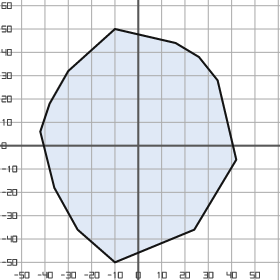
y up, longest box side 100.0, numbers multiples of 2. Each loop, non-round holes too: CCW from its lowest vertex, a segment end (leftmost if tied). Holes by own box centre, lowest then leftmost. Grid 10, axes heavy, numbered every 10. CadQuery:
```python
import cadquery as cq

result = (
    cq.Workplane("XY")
    .moveTo(-10.0, -50.0)
    .lineTo(24.0, -36.0)
    .lineTo(42.0, -6.0)
    .lineTo(34.0, 28.0)
    .lineTo(26.0, 38.0)
    .lineTo(16.0, 44.0)
    .lineTo(-10.0, 50.0)
    .lineTo(-30.0, 32.0)
    .lineTo(-38.0, 18.0)
    .lineTo(-42.0, 6.0)
    .lineTo(-36.0, -18.0)
    .lineTo(-26.0, -36.0)
    .close()
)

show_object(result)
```